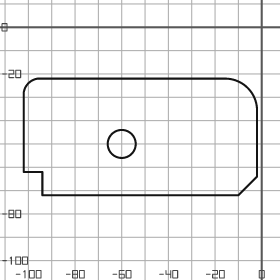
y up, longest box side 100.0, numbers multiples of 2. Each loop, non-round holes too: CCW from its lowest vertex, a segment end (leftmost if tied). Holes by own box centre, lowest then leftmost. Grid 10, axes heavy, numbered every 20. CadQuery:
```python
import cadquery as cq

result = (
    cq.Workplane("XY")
    .moveTo(-94.0, -72.0)
    .lineTo(-10.0, -72.0)
    .lineTo(-2.0, -64.0)
    .lineTo(-2.0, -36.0)
    .threePointArc((-6.0, -26.0), (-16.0, -22.0))
    .lineTo(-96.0, -22.0)
    .threePointArc((-100.0, -24.0), (-102.0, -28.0))
    .lineTo(-102.0, -62.0)
    .lineTo(-94.0, -62.0)
    .close()
    .moveTo(-60.0, -50.0)
    .circle(6.0)
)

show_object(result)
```